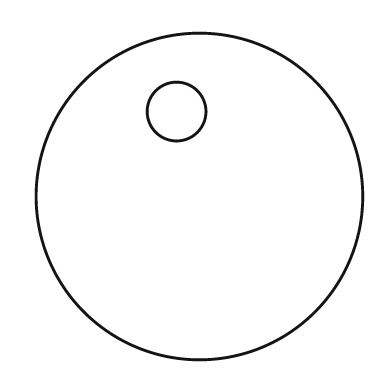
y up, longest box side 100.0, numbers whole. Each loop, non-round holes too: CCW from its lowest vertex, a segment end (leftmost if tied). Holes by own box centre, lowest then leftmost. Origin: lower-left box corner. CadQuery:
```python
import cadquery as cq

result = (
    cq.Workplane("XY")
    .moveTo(50.0, 50.0)
    .circle(50.0)
    .moveTo(43.0, 76.0)
    .circle(9.0)
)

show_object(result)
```